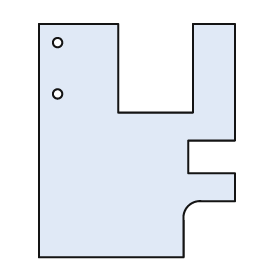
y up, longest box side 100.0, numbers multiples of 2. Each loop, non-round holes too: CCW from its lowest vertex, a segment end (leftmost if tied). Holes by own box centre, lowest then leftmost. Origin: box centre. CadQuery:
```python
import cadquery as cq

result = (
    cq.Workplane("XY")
    .moveTo(-42.0, -50.0)
    .lineTo(20.0, -50.0)
    .lineTo(20.0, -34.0)
    .threePointArc((22.0, -28.0), (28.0, -26.0))
    .lineTo(42.0, -26.0)
    .lineTo(42.0, -14.0)
    .lineTo(22.0, -14.0)
    .lineTo(22.0, 0.0)
    .lineTo(42.0, 0.0)
    .lineTo(42.0, 50.0)
    .lineTo(24.0, 50.0)
    .lineTo(24.0, 12.0)
    .lineTo(-8.0, 12.0)
    .lineTo(-8.0, 50.0)
    .lineTo(-42.0, 50.0)
    .close()
    .moveTo(-34.0, 20.0)
    .circle(2.0)
    .moveTo(-34.0, 42.0)
    .circle(2.0)
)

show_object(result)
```